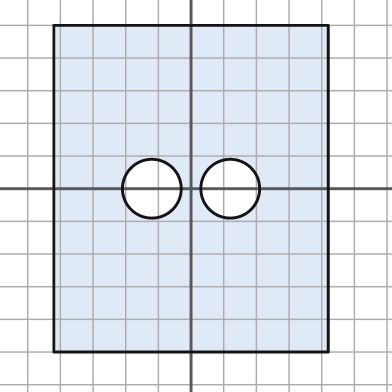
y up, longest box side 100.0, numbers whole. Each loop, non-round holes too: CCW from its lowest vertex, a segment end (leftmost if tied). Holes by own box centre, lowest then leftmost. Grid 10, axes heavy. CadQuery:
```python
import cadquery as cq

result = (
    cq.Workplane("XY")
    .moveTo(-42.0, -50.0)
    .lineTo(42.0, -50.0)
    .lineTo(42.0, 50.0)
    .lineTo(-42.0, 50.0)
    .close()
    .moveTo(-12.0, 0.0)
    .circle(9.0)
    .moveTo(12.0, 0.0)
    .circle(9.0)
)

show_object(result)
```